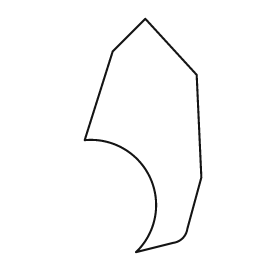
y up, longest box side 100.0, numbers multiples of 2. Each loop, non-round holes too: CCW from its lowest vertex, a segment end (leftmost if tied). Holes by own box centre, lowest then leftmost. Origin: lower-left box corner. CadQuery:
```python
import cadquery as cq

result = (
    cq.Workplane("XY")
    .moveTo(22.0, 0.0)
    .lineTo(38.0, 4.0)
    .threePointArc((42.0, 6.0), (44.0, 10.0))
    .lineTo(50.0, 32.0)
    .lineTo(48.0, 76.0)
    .lineTo(26.0, 100.0)
    .lineTo(12.0, 86.0)
    .lineTo(0.0, 48.0)
    .threePointArc((28.0, 32.0), (22.0, 0.0))
    .close()
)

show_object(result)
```